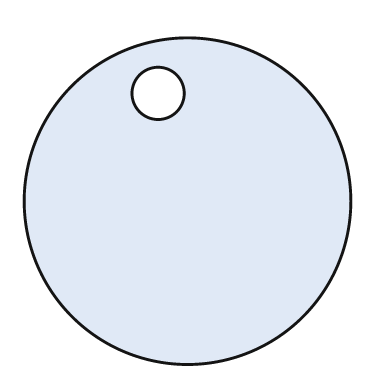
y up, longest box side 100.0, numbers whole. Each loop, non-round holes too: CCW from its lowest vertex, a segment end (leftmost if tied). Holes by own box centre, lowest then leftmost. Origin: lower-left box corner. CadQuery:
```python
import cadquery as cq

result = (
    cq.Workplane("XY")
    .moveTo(50.0, 50.0)
    .circle(50.0)
    .moveTo(41.0, 83.0)
    .circle(8.0)
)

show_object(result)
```